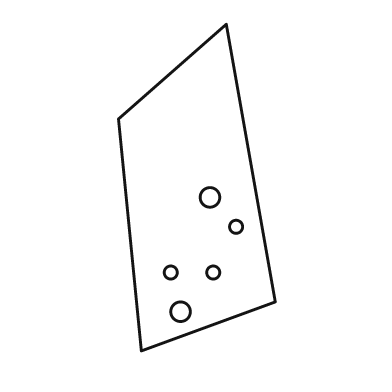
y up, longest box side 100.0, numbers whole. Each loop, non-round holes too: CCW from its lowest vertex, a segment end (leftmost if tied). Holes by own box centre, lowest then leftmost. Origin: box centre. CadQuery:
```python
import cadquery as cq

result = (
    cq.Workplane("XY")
    .moveTo(-17.0, -50.0)
    .lineTo(24.0, -35.0)
    .lineTo(9.0, 50.0)
    .lineTo(-24.0, 21.0)
    .close()
    .moveTo(-5.0, -38.0)
    .circle(3.0)
    .moveTo(-8.0, -26.0)
    .circle(2.0)
    .moveTo(5.0, -26.0)
    .circle(2.0)
    .moveTo(12.0, -12.0)
    .circle(2.0)
    .moveTo(4.0, -3.0)
    .circle(3.0)
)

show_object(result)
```